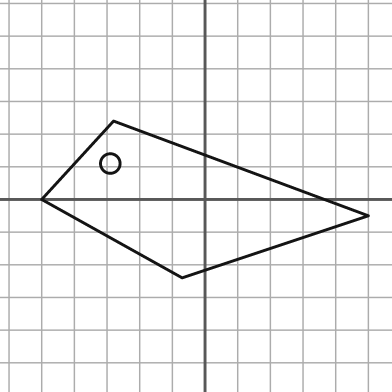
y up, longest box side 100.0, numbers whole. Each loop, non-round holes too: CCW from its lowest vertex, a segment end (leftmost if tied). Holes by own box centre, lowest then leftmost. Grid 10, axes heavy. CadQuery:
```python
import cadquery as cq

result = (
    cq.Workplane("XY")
    .moveTo(-7.0, -24.0)
    .lineTo(50.0, -5.0)
    .lineTo(-28.0, 24.0)
    .lineTo(-50.0, 0.0)
    .close()
    .moveTo(-29.0, 11.0)
    .circle(3.0)
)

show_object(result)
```